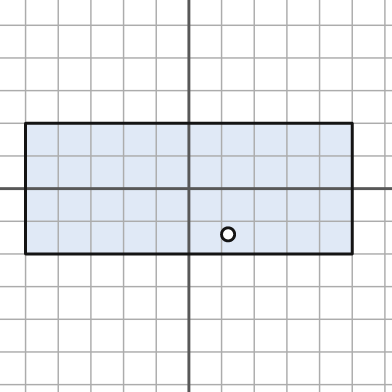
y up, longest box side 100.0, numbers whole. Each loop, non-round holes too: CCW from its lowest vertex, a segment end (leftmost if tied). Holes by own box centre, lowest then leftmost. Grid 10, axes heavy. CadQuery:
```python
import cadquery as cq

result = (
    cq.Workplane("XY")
    .moveTo(-50.0, -20.0)
    .lineTo(50.0, -20.0)
    .lineTo(50.0, 20.0)
    .lineTo(-50.0, 20.0)
    .close()
    .moveTo(12.0, -14.0)
    .circle(2.0)
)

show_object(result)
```